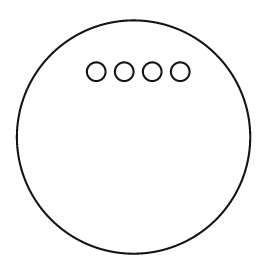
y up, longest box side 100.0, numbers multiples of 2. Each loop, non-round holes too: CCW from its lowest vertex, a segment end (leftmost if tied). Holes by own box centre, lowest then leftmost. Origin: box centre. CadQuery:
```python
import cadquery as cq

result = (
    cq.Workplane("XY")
    .moveTo(0.0, 0.0)
    .circle(50.0)
    .moveTo(-16.0, 28.0)
    .circle(4.0)
    .moveTo(-4.0, 28.0)
    .circle(4.0)
    .moveTo(8.0, 28.0)
    .circle(4.0)
    .moveTo(20.0, 28.0)
    .circle(4.0)
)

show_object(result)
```